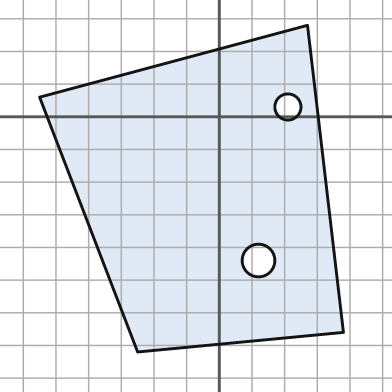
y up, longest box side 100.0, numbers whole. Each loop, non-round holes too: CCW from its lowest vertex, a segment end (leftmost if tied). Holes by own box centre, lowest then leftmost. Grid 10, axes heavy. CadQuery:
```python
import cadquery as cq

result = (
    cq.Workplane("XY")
    .moveTo(-25.0, -72.0)
    .lineTo(38.0, -66.0)
    .lineTo(27.0, 28.0)
    .lineTo(-55.0, 6.0)
    .close()
    .moveTo(12.0, -44.0)
    .circle(5.0)
    .moveTo(21.0, 3.0)
    .circle(4.0)
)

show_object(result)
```